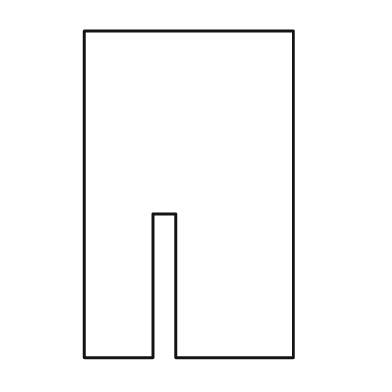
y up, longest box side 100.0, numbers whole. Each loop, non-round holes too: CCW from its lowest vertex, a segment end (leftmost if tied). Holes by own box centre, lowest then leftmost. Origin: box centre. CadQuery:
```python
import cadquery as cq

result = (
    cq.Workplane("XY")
    .moveTo(-32.0, -50.0)
    .lineTo(-11.0, -50.0)
    .lineTo(-11.0, -6.0)
    .lineTo(-4.0, -6.0)
    .lineTo(-4.0, -50.0)
    .lineTo(32.0, -50.0)
    .lineTo(32.0, 50.0)
    .lineTo(-32.0, 50.0)
    .close()
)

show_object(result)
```